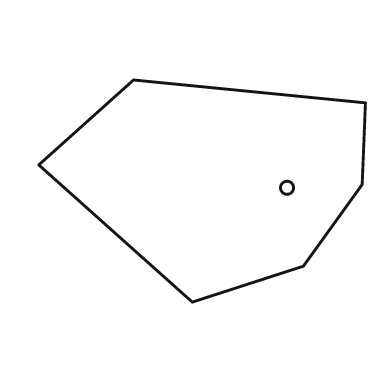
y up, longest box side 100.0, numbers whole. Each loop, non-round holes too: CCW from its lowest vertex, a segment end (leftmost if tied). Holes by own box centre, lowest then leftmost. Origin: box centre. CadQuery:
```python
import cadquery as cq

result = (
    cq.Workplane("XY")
    .moveTo(-3.0, -34.0)
    .lineTo(31.0, -23.0)
    .lineTo(49.0, 2.0)
    .lineTo(50.0, 27.0)
    .lineTo(-21.0, 34.0)
    .lineTo(-50.0, 8.0)
    .close()
    .moveTo(26.0, 1.0)
    .circle(2.0)
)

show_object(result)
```